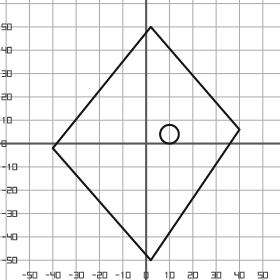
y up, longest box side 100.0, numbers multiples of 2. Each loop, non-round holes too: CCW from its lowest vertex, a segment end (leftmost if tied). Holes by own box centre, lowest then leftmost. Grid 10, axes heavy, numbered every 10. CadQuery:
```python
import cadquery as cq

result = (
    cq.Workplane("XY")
    .moveTo(2.0, -50.0)
    .lineTo(40.0, 6.0)
    .lineTo(2.0, 50.0)
    .lineTo(-40.0, -2.0)
    .close()
    .moveTo(10.0, 4.0)
    .circle(4.0)
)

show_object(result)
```